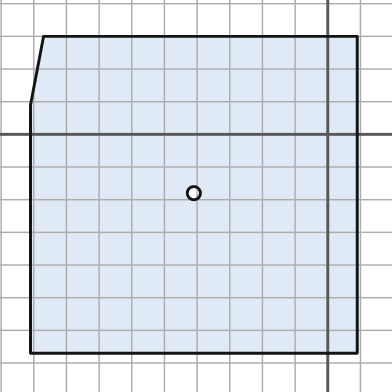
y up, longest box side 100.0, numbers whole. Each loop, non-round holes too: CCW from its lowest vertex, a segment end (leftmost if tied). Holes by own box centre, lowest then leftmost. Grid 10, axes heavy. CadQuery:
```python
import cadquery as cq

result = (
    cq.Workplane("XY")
    .moveTo(-91.0, -67.0)
    .lineTo(9.0, -67.0)
    .lineTo(9.0, 30.0)
    .lineTo(-87.0, 30.0)
    .lineTo(-91.0, 9.0)
    .close()
    .moveTo(-41.0, -18.0)
    .circle(2.0)
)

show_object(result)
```